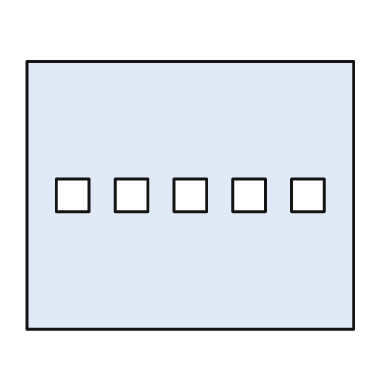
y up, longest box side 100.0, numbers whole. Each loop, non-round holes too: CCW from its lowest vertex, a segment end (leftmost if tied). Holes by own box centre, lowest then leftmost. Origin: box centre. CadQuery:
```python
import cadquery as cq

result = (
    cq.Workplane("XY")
    .moveTo(-50.0, -41.0)
    .lineTo(50.0, -41.0)
    .lineTo(50.0, 41.0)
    .lineTo(-50.0, 41.0)
    .close()
    .moveTo(-41.0, -5.0)
    .lineTo(-31.0, -5.0)
    .lineTo(-31.0, 5.0)
    .lineTo(-41.0, 5.0)
    .close()
    .moveTo(-23.0, -5.0)
    .lineTo(-13.0, -5.0)
    .lineTo(-13.0, 5.0)
    .lineTo(-23.0, 5.0)
    .close()
    .moveTo(-5.0, -5.0)
    .lineTo(5.0, -5.0)
    .lineTo(5.0, 5.0)
    .lineTo(-5.0, 5.0)
    .close()
    .moveTo(13.0, -5.0)
    .lineTo(23.0, -5.0)
    .lineTo(23.0, 5.0)
    .lineTo(13.0, 5.0)
    .close()
    .moveTo(31.0, -5.0)
    .lineTo(41.0, -5.0)
    .lineTo(41.0, 5.0)
    .lineTo(31.0, 5.0)
    .close()
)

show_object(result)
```